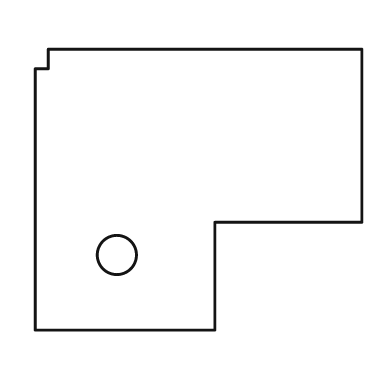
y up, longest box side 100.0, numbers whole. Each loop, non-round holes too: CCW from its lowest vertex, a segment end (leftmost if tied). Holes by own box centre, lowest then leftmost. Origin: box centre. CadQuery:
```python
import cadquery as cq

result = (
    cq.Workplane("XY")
    .moveTo(-50.0, -43.0)
    .lineTo(5.0, -43.0)
    .lineTo(5.0, -10.0)
    .lineTo(50.0, -10.0)
    .lineTo(50.0, 43.0)
    .lineTo(-46.0, 43.0)
    .lineTo(-46.0, 37.0)
    .lineTo(-50.0, 37.0)
    .close()
    .moveTo(-25.0, -20.0)
    .circle(6.0)
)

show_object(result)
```